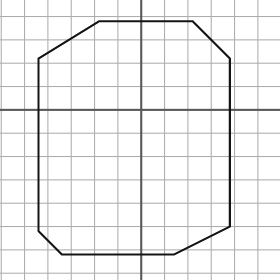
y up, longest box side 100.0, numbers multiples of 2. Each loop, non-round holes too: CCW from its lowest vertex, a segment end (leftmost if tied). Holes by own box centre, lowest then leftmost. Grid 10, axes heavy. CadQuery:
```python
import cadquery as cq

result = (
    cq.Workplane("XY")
    .moveTo(-34.0, -62.0)
    .lineTo(14.0, -62.0)
    .lineTo(38.0, -50.0)
    .lineTo(38.0, 22.0)
    .lineTo(22.0, 38.0)
    .lineTo(-18.0, 38.0)
    .lineTo(-44.0, 22.0)
    .lineTo(-44.0, -52.0)
    .close()
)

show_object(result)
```